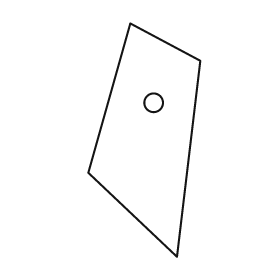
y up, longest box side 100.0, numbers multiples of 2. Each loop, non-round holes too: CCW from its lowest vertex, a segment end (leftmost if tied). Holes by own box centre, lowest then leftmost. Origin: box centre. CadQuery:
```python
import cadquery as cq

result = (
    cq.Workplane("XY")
    .moveTo(14.0, -50.0)
    .lineTo(24.0, 34.0)
    .lineTo(-6.0, 50.0)
    .lineTo(-24.0, -14.0)
    .close()
    .moveTo(4.0, 16.0)
    .circle(4.0)
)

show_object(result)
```